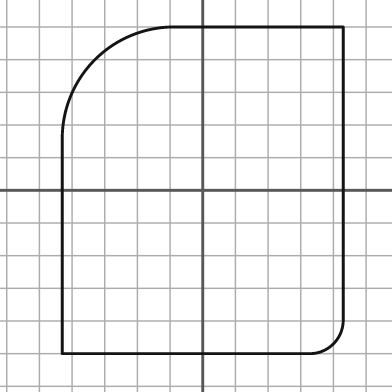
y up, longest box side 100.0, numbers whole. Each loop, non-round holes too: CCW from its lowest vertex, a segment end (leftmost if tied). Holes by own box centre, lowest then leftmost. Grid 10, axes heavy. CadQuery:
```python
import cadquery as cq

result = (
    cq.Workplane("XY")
    .moveTo(-43.0, -50.0)
    .lineTo(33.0, -50.0)
    .threePointArc((40.0, -47.0), (43.0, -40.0))
    .lineTo(43.0, 50.0)
    .lineTo(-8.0, 50.0)
    .threePointArc((-33.0, 40.0), (-43.0, 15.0))
    .close()
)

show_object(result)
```